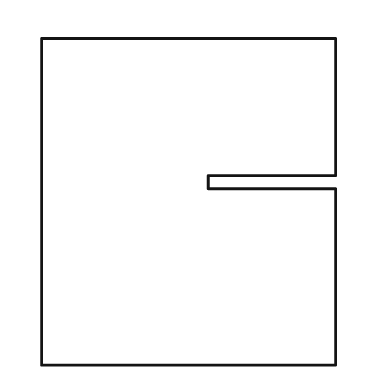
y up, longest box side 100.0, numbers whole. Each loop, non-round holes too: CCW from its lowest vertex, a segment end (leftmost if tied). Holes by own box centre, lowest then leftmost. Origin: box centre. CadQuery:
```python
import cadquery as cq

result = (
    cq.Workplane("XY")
    .moveTo(-45.0, -50.0)
    .lineTo(45.0, -50.0)
    .lineTo(45.0, 4.0)
    .lineTo(6.0, 4.0)
    .lineTo(6.0, 8.0)
    .lineTo(45.0, 8.0)
    .lineTo(45.0, 50.0)
    .lineTo(-45.0, 50.0)
    .close()
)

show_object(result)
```